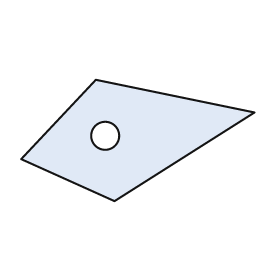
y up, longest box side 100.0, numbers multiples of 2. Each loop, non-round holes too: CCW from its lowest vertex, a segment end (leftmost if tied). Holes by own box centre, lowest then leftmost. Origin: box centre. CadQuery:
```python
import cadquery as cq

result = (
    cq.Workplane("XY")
    .moveTo(-10.0, -26.0)
    .lineTo(50.0, 12.0)
    .lineTo(-18.0, 26.0)
    .lineTo(-50.0, -8.0)
    .close()
    .moveTo(-14.0, 2.0)
    .circle(6.0)
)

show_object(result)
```